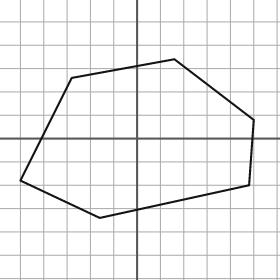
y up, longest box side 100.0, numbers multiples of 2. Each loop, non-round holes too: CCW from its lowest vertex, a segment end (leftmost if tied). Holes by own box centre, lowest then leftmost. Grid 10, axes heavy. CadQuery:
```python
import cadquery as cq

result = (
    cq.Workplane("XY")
    .moveTo(-16.0, -34.0)
    .lineTo(48.0, -20.0)
    .lineTo(50.0, 8.0)
    .lineTo(16.0, 34.0)
    .lineTo(-28.0, 26.0)
    .lineTo(-50.0, -18.0)
    .close()
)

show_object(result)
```